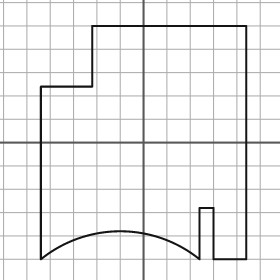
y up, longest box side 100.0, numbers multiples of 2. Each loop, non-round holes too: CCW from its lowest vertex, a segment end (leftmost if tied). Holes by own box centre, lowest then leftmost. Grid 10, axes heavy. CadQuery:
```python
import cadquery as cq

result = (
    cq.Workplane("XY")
    .moveTo(-44.0, -50.0)
    .threePointArc((-10.0, -38.0), (24.0, -50.0))
    .lineTo(24.0, -28.0)
    .lineTo(30.0, -28.0)
    .lineTo(30.0, -50.0)
    .lineTo(44.0, -50.0)
    .lineTo(44.0, 50.0)
    .lineTo(-22.0, 50.0)
    .lineTo(-22.0, 24.0)
    .lineTo(-44.0, 24.0)
    .close()
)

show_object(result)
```